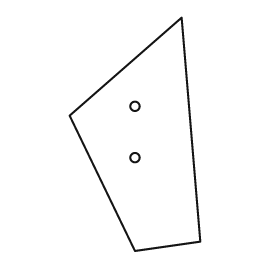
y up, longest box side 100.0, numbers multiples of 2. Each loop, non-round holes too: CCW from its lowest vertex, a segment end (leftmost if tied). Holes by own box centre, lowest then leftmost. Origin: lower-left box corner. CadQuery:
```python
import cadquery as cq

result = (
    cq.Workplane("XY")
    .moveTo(28.0, 0.0)
    .lineTo(56.0, 4.0)
    .lineTo(48.0, 100.0)
    .lineTo(0.0, 58.0)
    .close()
    .moveTo(28.0, 40.0)
    .circle(2.0)
    .moveTo(28.0, 62.0)
    .circle(2.0)
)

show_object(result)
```